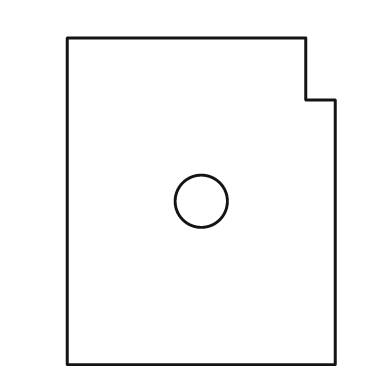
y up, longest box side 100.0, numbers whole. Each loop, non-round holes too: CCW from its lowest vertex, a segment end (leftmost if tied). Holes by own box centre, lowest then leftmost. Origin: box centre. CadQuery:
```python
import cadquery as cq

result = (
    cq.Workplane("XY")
    .moveTo(-41.0, -50.0)
    .lineTo(41.0, -50.0)
    .lineTo(41.0, 31.0)
    .lineTo(32.0, 31.0)
    .lineTo(32.0, 50.0)
    .lineTo(-41.0, 50.0)
    .close()
    .moveTo(0.0, 0.0)
    .circle(8.0)
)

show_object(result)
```